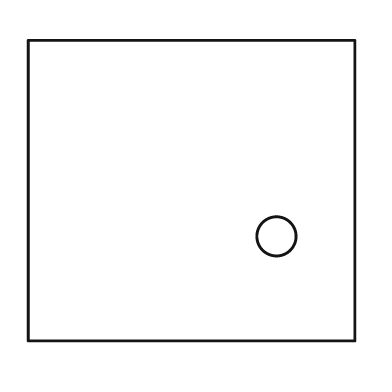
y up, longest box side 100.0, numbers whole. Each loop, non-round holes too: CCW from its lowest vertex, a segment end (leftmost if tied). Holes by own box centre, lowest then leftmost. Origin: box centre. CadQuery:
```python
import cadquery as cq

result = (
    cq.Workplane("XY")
    .moveTo(-50.0, -46.0)
    .lineTo(50.0, -46.0)
    .lineTo(50.0, 46.0)
    .lineTo(-50.0, 46.0)
    .close()
    .moveTo(26.0, -14.0)
    .circle(6.0)
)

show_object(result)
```